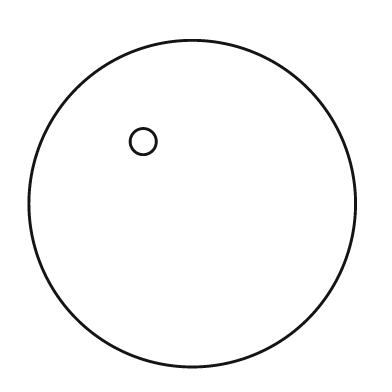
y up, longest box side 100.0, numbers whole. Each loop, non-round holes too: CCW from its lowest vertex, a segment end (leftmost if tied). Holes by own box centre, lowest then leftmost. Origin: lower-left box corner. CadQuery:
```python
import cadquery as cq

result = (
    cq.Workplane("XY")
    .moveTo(50.0, 50.0)
    .circle(50.0)
    .moveTo(35.0, 69.0)
    .circle(4.0)
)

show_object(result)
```